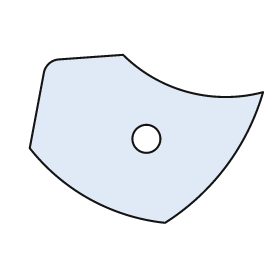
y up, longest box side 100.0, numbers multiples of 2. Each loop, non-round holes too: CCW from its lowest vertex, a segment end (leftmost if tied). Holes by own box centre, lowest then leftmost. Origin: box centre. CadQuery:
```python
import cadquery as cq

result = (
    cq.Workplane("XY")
    .moveTo(8.0, -36.0)
    .threePointArc((34.0, -12.0), (50.0, 20.0))
    .threePointArc((18.0, 20.0), (-10.0, 36.0))
    .lineTo(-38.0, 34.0)
    .threePointArc((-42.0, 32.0), (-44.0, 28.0))
    .lineTo(-50.0, -4.0)
    .threePointArc((-24.0, -26.0), (8.0, -36.0))
    .close()
    .moveTo(0.0, 0.0)
    .circle(6.0)
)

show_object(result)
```